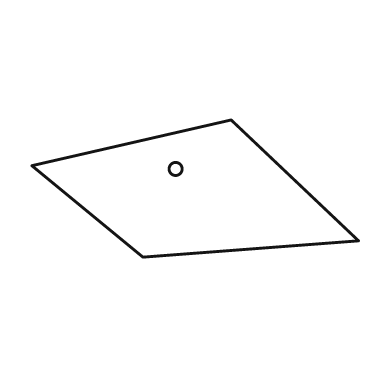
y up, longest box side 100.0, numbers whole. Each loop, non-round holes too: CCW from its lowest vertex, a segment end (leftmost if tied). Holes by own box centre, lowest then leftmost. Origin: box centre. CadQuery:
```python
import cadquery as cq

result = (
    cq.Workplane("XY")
    .moveTo(-16.0, -21.0)
    .lineTo(50.0, -16.0)
    .lineTo(11.0, 21.0)
    .lineTo(-50.0, 7.0)
    .close()
    .moveTo(-6.0, 6.0)
    .circle(2.0)
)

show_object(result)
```